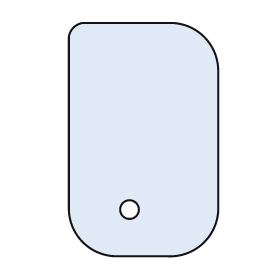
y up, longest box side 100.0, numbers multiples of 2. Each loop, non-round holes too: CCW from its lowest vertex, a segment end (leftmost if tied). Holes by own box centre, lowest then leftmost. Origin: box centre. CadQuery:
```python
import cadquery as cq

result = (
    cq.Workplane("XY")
    .moveTo(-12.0, -50.0)
    .lineTo(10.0, -50.0)
    .threePointArc((26.0, -44.0), (32.0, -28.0))
    .lineTo(32.0, 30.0)
    .threePointArc((26.0, 44.0), (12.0, 50.0))
    .lineTo(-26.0, 50.0)
    .threePointArc((-30.0, 48.0), (-32.0, 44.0))
    .lineTo(-32.0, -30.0)
    .threePointArc((-26.0, -44.0), (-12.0, -50.0))
    .close()
    .moveTo(-6.0, -30.0)
    .circle(4.0)
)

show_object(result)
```